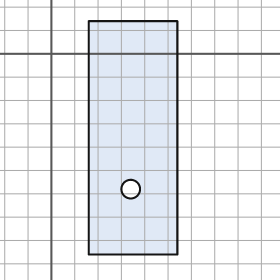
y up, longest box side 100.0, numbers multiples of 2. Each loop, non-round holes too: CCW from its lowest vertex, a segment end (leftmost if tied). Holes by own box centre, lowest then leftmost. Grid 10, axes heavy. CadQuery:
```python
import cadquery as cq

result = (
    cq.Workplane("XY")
    .moveTo(16.0, -86.0)
    .lineTo(54.0, -86.0)
    .lineTo(54.0, 14.0)
    .lineTo(16.0, 14.0)
    .close()
    .moveTo(34.0, -58.0)
    .circle(4.0)
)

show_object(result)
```